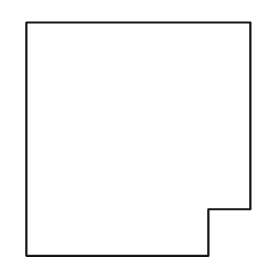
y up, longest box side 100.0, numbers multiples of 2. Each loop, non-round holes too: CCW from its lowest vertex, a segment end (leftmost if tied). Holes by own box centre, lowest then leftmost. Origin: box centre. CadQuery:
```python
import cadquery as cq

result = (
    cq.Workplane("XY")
    .moveTo(-48.0, -50.0)
    .lineTo(30.0, -50.0)
    .lineTo(30.0, -30.0)
    .lineTo(48.0, -30.0)
    .lineTo(48.0, 50.0)
    .lineTo(-48.0, 50.0)
    .close()
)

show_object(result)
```